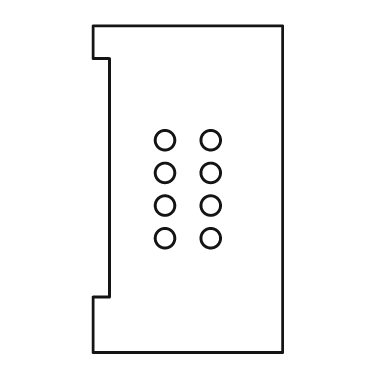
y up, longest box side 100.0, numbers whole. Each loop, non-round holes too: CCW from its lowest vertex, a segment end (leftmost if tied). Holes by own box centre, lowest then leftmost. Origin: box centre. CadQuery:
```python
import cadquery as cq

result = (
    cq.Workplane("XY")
    .moveTo(-29.0, -50.0)
    .lineTo(29.0, -50.0)
    .lineTo(29.0, 50.0)
    .lineTo(-29.0, 50.0)
    .lineTo(-29.0, 40.0)
    .lineTo(-24.0, 40.0)
    .lineTo(-24.0, -33.0)
    .lineTo(-29.0, -33.0)
    .close()
    .moveTo(-7.0, -15.0)
    .circle(3.0)
    .moveTo(7.0, -15.0)
    .circle(3.0)
    .moveTo(-7.0, -5.0)
    .circle(3.0)
    .moveTo(7.0, -5.0)
    .circle(3.0)
    .moveTo(-7.0, 5.0)
    .circle(3.0)
    .moveTo(7.0, 5.0)
    .circle(3.0)
    .moveTo(-7.0, 15.0)
    .circle(3.0)
    .moveTo(7.0, 15.0)
    .circle(3.0)
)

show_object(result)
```